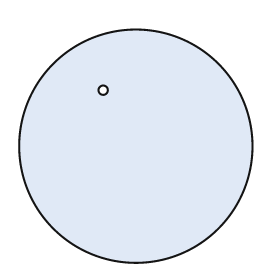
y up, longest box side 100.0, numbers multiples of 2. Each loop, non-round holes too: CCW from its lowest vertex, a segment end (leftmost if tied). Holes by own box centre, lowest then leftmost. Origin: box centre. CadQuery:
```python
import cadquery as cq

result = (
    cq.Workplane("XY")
    .moveTo(0.0, 0.0)
    .circle(50.0)
    .moveTo(-14.0, 24.0)
    .circle(2.0)
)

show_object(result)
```